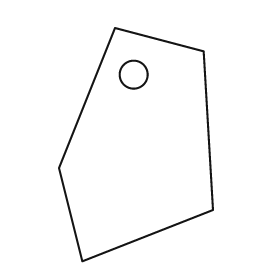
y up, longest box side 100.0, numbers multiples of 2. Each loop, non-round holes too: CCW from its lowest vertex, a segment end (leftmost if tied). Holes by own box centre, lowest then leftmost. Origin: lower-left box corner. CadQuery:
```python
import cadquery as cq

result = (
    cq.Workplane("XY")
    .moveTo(10.0, 0.0)
    .lineTo(66.0, 22.0)
    .lineTo(62.0, 90.0)
    .lineTo(24.0, 100.0)
    .lineTo(0.0, 40.0)
    .close()
    .moveTo(32.0, 80.0)
    .circle(6.0)
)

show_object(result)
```